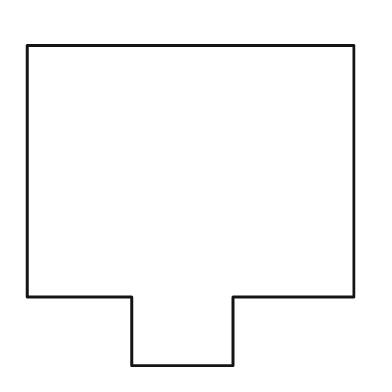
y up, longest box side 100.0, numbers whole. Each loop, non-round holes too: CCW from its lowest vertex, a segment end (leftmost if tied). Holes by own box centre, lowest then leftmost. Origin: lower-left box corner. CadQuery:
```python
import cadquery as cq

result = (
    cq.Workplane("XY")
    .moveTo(32.0, 0.0)
    .lineTo(63.0, 0.0)
    .lineTo(63.0, 21.0)
    .lineTo(100.0, 21.0)
    .lineTo(100.0, 98.0)
    .lineTo(0.0, 98.0)
    .lineTo(0.0, 21.0)
    .lineTo(32.0, 21.0)
    .close()
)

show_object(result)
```